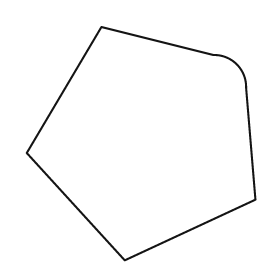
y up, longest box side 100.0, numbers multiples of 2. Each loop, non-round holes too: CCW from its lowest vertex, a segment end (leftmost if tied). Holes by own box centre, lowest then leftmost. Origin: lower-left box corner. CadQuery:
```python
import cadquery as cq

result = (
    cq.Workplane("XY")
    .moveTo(42.0, 0.0)
    .lineTo(98.0, 26.0)
    .lineTo(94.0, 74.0)
    .threePointArc((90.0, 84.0), (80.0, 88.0))
    .lineTo(32.0, 100.0)
    .lineTo(0.0, 46.0)
    .close()
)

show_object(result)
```